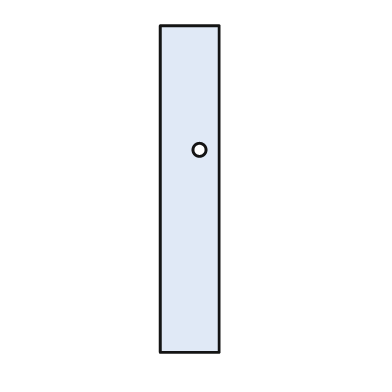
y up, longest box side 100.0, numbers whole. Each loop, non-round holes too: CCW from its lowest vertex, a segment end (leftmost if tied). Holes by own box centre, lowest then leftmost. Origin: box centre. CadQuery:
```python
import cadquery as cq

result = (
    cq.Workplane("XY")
    .moveTo(-9.0, -50.0)
    .lineTo(9.0, -50.0)
    .lineTo(9.0, 50.0)
    .lineTo(-9.0, 50.0)
    .close()
    .moveTo(3.0, 12.0)
    .circle(2.0)
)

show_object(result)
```